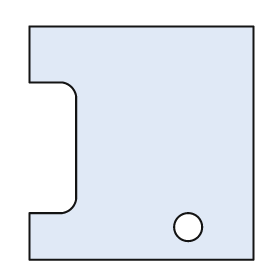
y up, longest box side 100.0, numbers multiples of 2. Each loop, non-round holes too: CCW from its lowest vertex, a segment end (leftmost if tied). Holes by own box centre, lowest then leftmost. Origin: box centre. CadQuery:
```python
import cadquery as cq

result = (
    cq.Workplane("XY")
    .moveTo(-48.0, -50.0)
    .lineTo(48.0, -50.0)
    .lineTo(48.0, 50.0)
    .lineTo(-48.0, 50.0)
    .lineTo(-48.0, 26.0)
    .lineTo(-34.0, 26.0)
    .threePointArc((-30.0, 24.0), (-28.0, 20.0))
    .lineTo(-28.0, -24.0)
    .threePointArc((-30.0, -28.0), (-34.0, -30.0))
    .lineTo(-48.0, -30.0)
    .close()
    .moveTo(20.0, -36.0)
    .circle(6.0)
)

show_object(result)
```